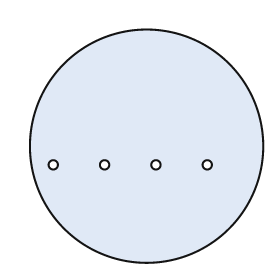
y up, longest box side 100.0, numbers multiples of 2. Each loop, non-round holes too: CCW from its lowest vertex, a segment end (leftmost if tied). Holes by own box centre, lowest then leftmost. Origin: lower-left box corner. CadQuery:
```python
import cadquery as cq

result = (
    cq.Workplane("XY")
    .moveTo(50.0, 50.0)
    .circle(50.0)
    .moveTo(10.0, 42.0)
    .circle(2.0)
    .moveTo(32.0, 42.0)
    .circle(2.0)
    .moveTo(54.0, 42.0)
    .circle(2.0)
    .moveTo(76.0, 42.0)
    .circle(2.0)
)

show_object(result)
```